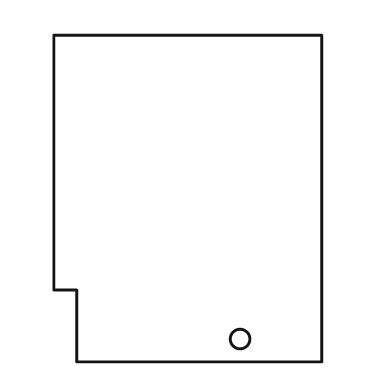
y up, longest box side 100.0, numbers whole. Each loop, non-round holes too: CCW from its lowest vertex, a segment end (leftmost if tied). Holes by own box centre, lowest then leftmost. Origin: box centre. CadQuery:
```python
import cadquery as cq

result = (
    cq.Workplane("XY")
    .moveTo(-34.0, -50.0)
    .lineTo(41.0, -50.0)
    .lineTo(41.0, 50.0)
    .lineTo(-41.0, 50.0)
    .lineTo(-41.0, -28.0)
    .lineTo(-34.0, -28.0)
    .close()
    .moveTo(16.0, -43.0)
    .circle(3.0)
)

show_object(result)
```